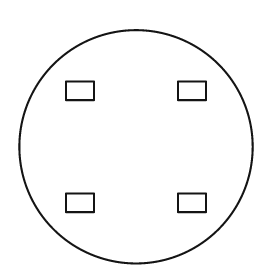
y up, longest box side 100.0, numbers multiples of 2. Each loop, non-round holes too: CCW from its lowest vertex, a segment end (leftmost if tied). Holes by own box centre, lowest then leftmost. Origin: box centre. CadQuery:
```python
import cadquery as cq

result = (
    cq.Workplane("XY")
    .moveTo(0.0, 0.0)
    .circle(50.0)
    .moveTo(-30.0, -28.0)
    .lineTo(-18.0, -28.0)
    .lineTo(-18.0, -20.0)
    .lineTo(-30.0, -20.0)
    .close()
    .moveTo(18.0, -28.0)
    .lineTo(30.0, -28.0)
    .lineTo(30.0, -20.0)
    .lineTo(18.0, -20.0)
    .close()
    .moveTo(-30.0, 20.0)
    .lineTo(-18.0, 20.0)
    .lineTo(-18.0, 28.0)
    .lineTo(-30.0, 28.0)
    .close()
    .moveTo(18.0, 20.0)
    .lineTo(30.0, 20.0)
    .lineTo(30.0, 28.0)
    .lineTo(18.0, 28.0)
    .close()
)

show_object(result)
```